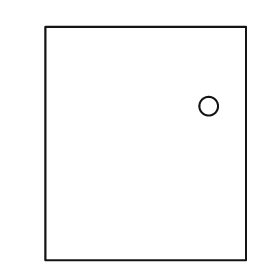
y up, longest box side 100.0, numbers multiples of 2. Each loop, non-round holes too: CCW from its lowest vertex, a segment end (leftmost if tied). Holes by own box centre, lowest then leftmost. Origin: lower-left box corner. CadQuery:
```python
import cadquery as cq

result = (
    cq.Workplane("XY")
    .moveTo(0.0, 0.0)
    .lineTo(86.0, 0.0)
    .lineTo(86.0, 100.0)
    .lineTo(0.0, 100.0)
    .close()
    .moveTo(70.0, 66.0)
    .circle(4.0)
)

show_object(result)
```